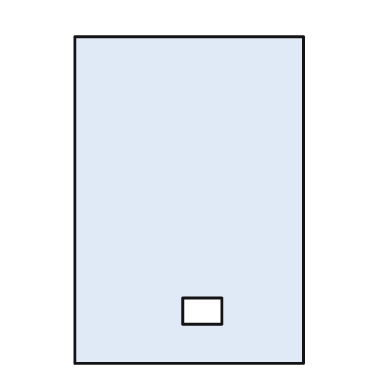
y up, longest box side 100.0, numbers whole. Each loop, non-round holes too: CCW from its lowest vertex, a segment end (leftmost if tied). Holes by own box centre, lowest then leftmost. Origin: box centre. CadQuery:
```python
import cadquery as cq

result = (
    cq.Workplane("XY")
    .moveTo(-35.0, -50.0)
    .lineTo(35.0, -50.0)
    .lineTo(35.0, 50.0)
    .lineTo(-35.0, 50.0)
    .close()
    .moveTo(-2.0, -38.0)
    .lineTo(10.0, -38.0)
    .lineTo(10.0, -30.0)
    .lineTo(-2.0, -30.0)
    .close()
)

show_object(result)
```